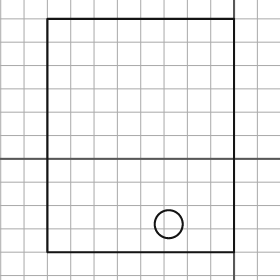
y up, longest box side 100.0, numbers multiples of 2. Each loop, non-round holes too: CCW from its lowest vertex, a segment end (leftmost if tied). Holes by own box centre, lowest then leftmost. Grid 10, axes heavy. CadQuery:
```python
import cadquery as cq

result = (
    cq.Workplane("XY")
    .moveTo(-80.0, -40.0)
    .lineTo(0.0, -40.0)
    .lineTo(0.0, 60.0)
    .lineTo(-80.0, 60.0)
    .close()
    .moveTo(-28.0, -28.0)
    .circle(6.0)
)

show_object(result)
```